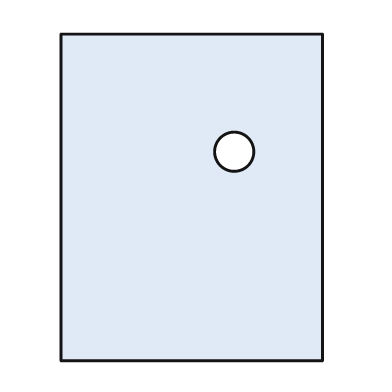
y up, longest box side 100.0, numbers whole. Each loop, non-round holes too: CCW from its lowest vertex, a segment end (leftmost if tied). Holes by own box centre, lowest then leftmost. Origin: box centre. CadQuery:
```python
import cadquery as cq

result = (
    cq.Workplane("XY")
    .moveTo(-40.0, -50.0)
    .lineTo(40.0, -50.0)
    .lineTo(40.0, 50.0)
    .lineTo(-40.0, 50.0)
    .close()
    .moveTo(13.0, 14.0)
    .circle(6.0)
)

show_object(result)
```